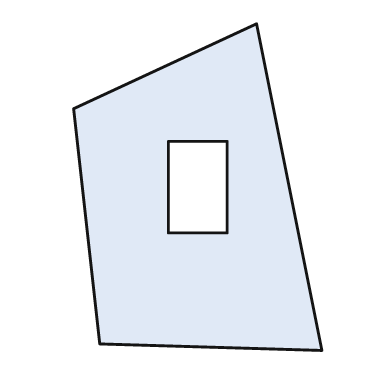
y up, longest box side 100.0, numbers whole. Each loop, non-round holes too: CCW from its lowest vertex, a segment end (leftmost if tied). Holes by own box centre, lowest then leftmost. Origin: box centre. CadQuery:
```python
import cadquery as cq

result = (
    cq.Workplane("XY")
    .moveTo(38.0, -50.0)
    .lineTo(18.0, 50.0)
    .lineTo(-38.0, 24.0)
    .lineTo(-30.0, -48.0)
    .close()
    .moveTo(-9.0, -14.0)
    .lineTo(9.0, -14.0)
    .lineTo(9.0, 14.0)
    .lineTo(-9.0, 14.0)
    .close()
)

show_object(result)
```